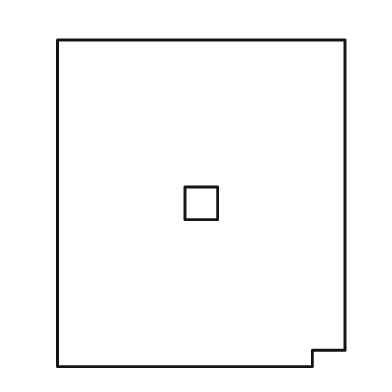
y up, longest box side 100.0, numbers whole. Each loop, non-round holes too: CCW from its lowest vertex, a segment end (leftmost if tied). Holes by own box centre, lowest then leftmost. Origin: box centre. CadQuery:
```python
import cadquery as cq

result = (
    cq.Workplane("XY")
    .moveTo(-44.0, -50.0)
    .lineTo(34.0, -50.0)
    .lineTo(34.0, -45.0)
    .lineTo(44.0, -45.0)
    .lineTo(44.0, 50.0)
    .lineTo(-44.0, 50.0)
    .close()
    .moveTo(-5.0, -5.0)
    .lineTo(5.0, -5.0)
    .lineTo(5.0, 5.0)
    .lineTo(-5.0, 5.0)
    .close()
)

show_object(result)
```